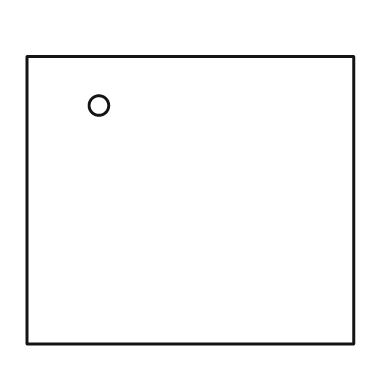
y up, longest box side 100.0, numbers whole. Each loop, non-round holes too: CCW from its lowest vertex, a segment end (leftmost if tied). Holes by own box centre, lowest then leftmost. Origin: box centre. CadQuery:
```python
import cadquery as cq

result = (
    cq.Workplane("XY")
    .moveTo(-50.0, -44.0)
    .lineTo(50.0, -44.0)
    .lineTo(50.0, 44.0)
    .lineTo(-50.0, 44.0)
    .close()
    .moveTo(-28.0, 29.0)
    .circle(3.0)
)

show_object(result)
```